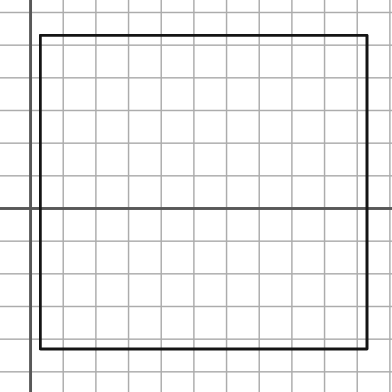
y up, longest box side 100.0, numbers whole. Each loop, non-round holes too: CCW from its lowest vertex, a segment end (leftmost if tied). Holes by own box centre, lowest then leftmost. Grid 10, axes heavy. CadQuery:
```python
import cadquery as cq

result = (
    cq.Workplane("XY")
    .moveTo(3.0, -43.0)
    .lineTo(103.0, -43.0)
    .lineTo(103.0, 53.0)
    .lineTo(3.0, 53.0)
    .close()
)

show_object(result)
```